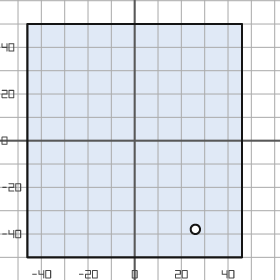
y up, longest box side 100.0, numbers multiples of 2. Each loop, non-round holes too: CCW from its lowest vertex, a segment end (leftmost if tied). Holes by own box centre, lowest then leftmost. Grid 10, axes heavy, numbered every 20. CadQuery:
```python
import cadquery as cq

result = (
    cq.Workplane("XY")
    .moveTo(-46.0, -50.0)
    .lineTo(46.0, -50.0)
    .lineTo(46.0, 50.0)
    .lineTo(-46.0, 50.0)
    .close()
    .moveTo(26.0, -38.0)
    .circle(2.0)
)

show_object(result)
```